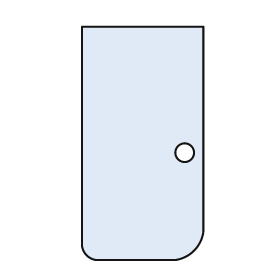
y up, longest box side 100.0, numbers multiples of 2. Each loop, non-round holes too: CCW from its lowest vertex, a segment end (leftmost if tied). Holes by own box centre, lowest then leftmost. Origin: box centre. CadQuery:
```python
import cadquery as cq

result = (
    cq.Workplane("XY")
    .moveTo(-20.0, -50.0)
    .lineTo(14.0, -50.0)
    .threePointArc((22.0, -46.0), (26.0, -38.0))
    .lineTo(26.0, 50.0)
    .lineTo(-26.0, 50.0)
    .lineTo(-26.0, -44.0)
    .threePointArc((-24.0, -48.0), (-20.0, -50.0))
    .close()
    .moveTo(18.0, -4.0)
    .circle(4.0)
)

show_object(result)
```